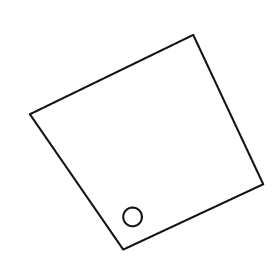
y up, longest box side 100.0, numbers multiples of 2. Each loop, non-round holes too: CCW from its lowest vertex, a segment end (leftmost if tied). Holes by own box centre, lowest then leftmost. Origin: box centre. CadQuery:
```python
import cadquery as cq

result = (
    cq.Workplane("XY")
    .moveTo(-10.0, -46.0)
    .lineTo(50.0, -18.0)
    .lineTo(20.0, 46.0)
    .lineTo(-50.0, 12.0)
    .close()
    .moveTo(-6.0, -32.0)
    .circle(4.0)
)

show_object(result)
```